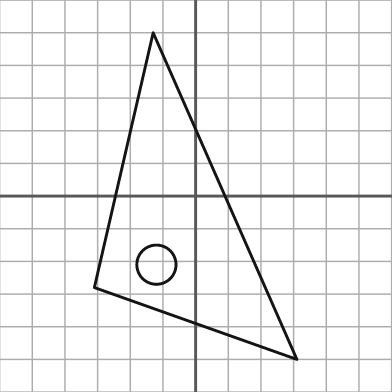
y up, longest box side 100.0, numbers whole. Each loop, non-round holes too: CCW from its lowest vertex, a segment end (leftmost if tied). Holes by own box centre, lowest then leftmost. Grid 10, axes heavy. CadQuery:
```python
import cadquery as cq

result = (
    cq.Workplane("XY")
    .moveTo(31.0, -50.0)
    .lineTo(-13.0, 50.0)
    .lineTo(-31.0, -28.0)
    .close()
    .moveTo(-12.0, -21.0)
    .circle(6.0)
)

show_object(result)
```